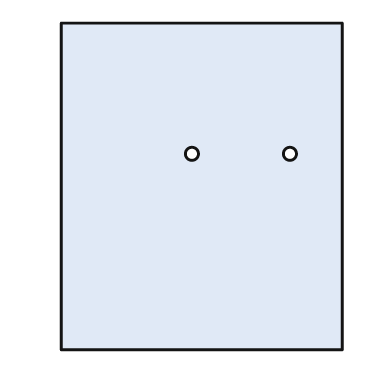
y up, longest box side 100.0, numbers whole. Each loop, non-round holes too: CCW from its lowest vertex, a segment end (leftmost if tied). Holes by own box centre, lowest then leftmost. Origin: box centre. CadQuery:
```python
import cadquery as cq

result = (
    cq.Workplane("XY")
    .moveTo(-43.0, -50.0)
    .lineTo(43.0, -50.0)
    .lineTo(43.0, 50.0)
    .lineTo(-43.0, 50.0)
    .close()
    .moveTo(-3.0, 10.0)
    .circle(2.0)
    .moveTo(27.0, 10.0)
    .circle(2.0)
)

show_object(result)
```